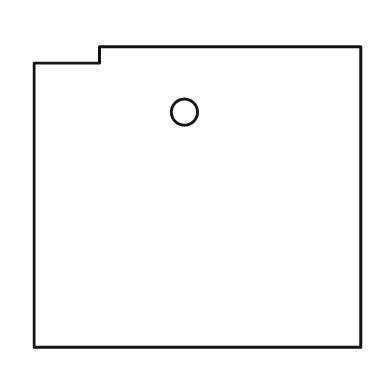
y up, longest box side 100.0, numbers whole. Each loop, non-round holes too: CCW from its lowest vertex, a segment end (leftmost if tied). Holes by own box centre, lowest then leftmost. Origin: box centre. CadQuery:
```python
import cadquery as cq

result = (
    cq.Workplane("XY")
    .moveTo(-50.0, -46.0)
    .lineTo(50.0, -46.0)
    .lineTo(50.0, 46.0)
    .lineTo(-30.0, 46.0)
    .lineTo(-30.0, 41.0)
    .lineTo(-50.0, 41.0)
    .close()
    .moveTo(-4.0, 26.0)
    .circle(4.0)
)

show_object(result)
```